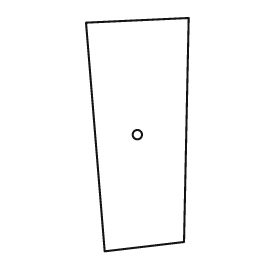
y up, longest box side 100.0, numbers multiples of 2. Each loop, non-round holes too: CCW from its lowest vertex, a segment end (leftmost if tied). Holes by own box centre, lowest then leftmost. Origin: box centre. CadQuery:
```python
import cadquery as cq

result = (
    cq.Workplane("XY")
    .moveTo(-14.0, -50.0)
    .lineTo(20.0, -46.0)
    .lineTo(22.0, 50.0)
    .lineTo(-22.0, 48.0)
    .close()
    .moveTo(0.0, 0.0)
    .circle(2.0)
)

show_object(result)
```